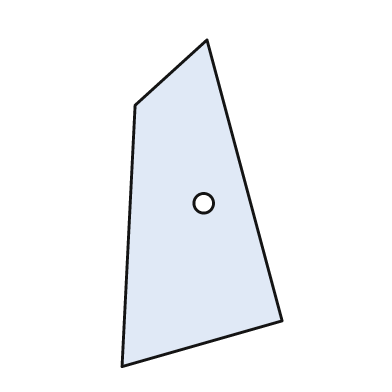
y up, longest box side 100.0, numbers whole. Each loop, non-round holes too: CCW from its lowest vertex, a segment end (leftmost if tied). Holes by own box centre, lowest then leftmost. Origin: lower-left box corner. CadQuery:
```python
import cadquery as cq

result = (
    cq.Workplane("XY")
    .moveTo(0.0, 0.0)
    .lineTo(49.0, 14.0)
    .lineTo(26.0, 100.0)
    .lineTo(4.0, 80.0)
    .close()
    .moveTo(25.0, 50.0)
    .circle(3.0)
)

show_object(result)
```